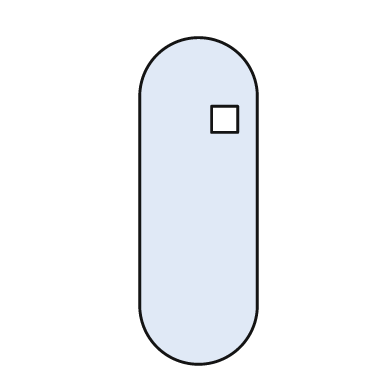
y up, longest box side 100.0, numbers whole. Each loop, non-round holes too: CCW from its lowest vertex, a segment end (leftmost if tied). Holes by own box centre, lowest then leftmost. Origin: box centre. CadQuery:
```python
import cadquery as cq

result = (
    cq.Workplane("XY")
    .moveTo(-18.0, -32.0)
    .threePointArc((0.0, -50.0), (18.0, -32.0))
    .lineTo(18.0, 32.0)
    .threePointArc((0.0, 50.0), (-18.0, 32.0))
    .close()
    .moveTo(4.0, 21.0)
    .lineTo(12.0, 21.0)
    .lineTo(12.0, 29.0)
    .lineTo(4.0, 29.0)
    .close()
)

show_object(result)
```